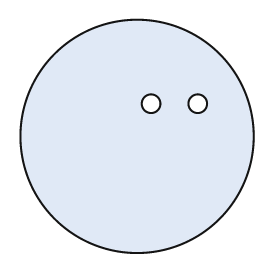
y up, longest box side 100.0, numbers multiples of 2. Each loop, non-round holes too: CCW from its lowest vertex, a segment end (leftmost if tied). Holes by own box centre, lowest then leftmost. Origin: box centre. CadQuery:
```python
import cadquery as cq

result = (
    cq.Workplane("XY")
    .moveTo(0.0, 0.0)
    .circle(50.0)
    .moveTo(6.0, 14.0)
    .circle(4.0)
    .moveTo(26.0, 14.0)
    .circle(4.0)
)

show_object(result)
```